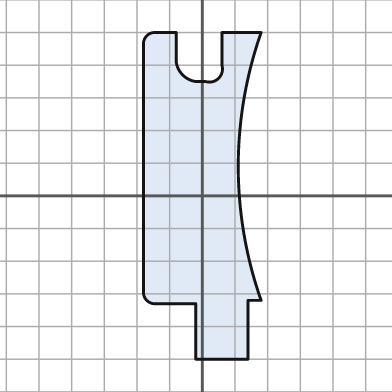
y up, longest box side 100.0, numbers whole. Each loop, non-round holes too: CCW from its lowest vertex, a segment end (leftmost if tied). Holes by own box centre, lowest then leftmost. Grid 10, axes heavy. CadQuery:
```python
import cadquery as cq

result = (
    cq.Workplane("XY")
    .moveTo(-2.0, -50.0)
    .lineTo(14.0, -50.0)
    .lineTo(14.0, -32.0)
    .lineTo(18.0, -32.0)
    .threePointArc((11.0, 9.0), (18.0, 50.0))
    .lineTo(6.0, 50.0)
    .lineTo(6.0, 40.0)
    .threePointArc((5.0, 36.0), (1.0, 35.0))
    .lineTo(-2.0, 35.0)
    .threePointArc((-6.0, 37.0), (-8.0, 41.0))
    .lineTo(-8.0, 50.0)
    .lineTo(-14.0, 50.0)
    .threePointArc((-17.0, 49.0), (-18.0, 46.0))
    .lineTo(-18.0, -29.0)
    .threePointArc((-17.0, -32.0), (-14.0, -33.0))
    .lineTo(-2.0, -33.0)
    .close()
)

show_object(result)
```